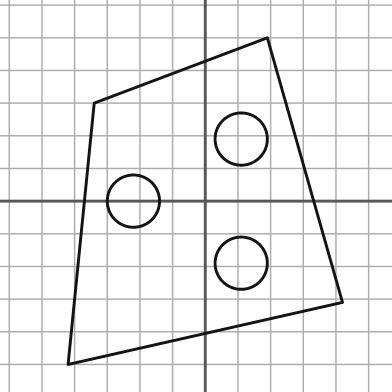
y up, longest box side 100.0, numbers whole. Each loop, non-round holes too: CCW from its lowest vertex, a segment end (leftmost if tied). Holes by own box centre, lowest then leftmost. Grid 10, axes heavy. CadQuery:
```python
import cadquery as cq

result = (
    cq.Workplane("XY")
    .moveTo(-42.0, -50.0)
    .lineTo(42.0, -31.0)
    .lineTo(19.0, 50.0)
    .lineTo(-34.0, 30.0)
    .close()
    .moveTo(11.0, -19.0)
    .circle(8.0)
    .moveTo(-22.0, 0.0)
    .circle(8.0)
    .moveTo(11.0, 19.0)
    .circle(8.0)
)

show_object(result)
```